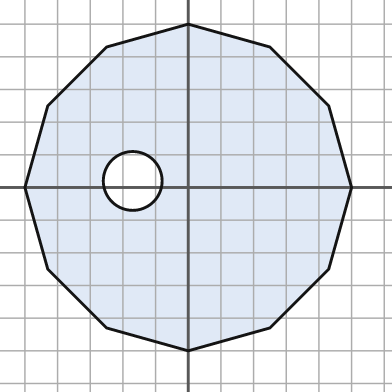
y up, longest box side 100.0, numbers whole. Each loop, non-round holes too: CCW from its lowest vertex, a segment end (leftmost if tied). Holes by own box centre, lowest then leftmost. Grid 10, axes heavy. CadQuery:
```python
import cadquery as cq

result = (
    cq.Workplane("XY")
    .moveTo(0.0, -50.0)
    .lineTo(25.0, -43.0)
    .lineTo(43.0, -25.0)
    .lineTo(50.0, 0.0)
    .lineTo(43.0, 25.0)
    .lineTo(25.0, 43.0)
    .lineTo(0.0, 50.0)
    .lineTo(-25.0, 43.0)
    .lineTo(-43.0, 25.0)
    .lineTo(-50.0, 0.0)
    .lineTo(-43.0, -25.0)
    .lineTo(-25.0, -43.0)
    .close()
    .moveTo(-17.0, 2.0)
    .circle(9.0)
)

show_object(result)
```